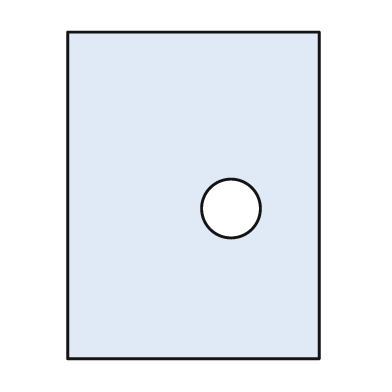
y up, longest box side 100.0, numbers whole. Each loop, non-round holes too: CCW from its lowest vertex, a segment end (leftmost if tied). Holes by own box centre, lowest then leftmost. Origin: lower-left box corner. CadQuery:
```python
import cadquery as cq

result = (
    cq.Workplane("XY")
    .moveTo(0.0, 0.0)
    .lineTo(77.0, 0.0)
    .lineTo(77.0, 100.0)
    .lineTo(0.0, 100.0)
    .close()
    .moveTo(50.0, 46.0)
    .circle(9.0)
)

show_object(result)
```